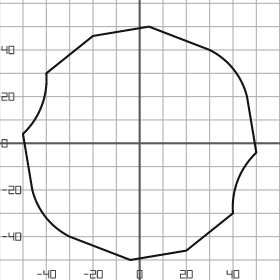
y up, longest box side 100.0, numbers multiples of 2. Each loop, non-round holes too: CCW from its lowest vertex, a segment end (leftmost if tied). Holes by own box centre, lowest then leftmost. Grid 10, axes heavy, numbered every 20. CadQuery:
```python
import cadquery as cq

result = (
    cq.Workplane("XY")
    .moveTo(-4.0, -50.0)
    .lineTo(20.0, -46.0)
    .lineTo(40.0, -30.0)
    .threePointArc((42.0, -16.0), (50.0, -4.0))
    .lineTo(46.0, 20.0)
    .threePointArc((40.0, 32.0), (30.0, 40.0))
    .lineTo(4.0, 50.0)
    .lineTo(-20.0, 46.0)
    .lineTo(-40.0, 30.0)
    .threePointArc((-42.0, 16.0), (-50.0, 4.0))
    .lineTo(-46.0, -20.0)
    .threePointArc((-40.0, -32.0), (-30.0, -40.0))
    .close()
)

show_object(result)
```